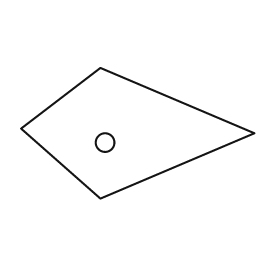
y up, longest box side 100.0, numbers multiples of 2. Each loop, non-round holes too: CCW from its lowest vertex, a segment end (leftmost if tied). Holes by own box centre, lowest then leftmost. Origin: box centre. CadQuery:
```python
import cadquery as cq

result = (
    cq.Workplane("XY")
    .moveTo(-16.0, -28.0)
    .lineTo(50.0, 0.0)
    .lineTo(-16.0, 28.0)
    .lineTo(-50.0, 2.0)
    .close()
    .moveTo(-14.0, -4.0)
    .circle(4.0)
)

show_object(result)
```